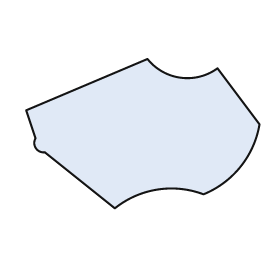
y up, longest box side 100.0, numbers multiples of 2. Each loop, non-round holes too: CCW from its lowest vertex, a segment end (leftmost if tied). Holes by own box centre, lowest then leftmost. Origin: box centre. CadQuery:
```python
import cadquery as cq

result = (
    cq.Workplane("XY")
    .moveTo(-12.0, -32.0)
    .threePointArc((6.0, -24.0), (26.0, -26.0))
    .threePointArc((42.0, -14.0), (50.0, 4.0))
    .lineTo(32.0, 28.0)
    .threePointArc((16.0, 24.0), (2.0, 32.0))
    .lineTo(-50.0, 10.0)
    .lineTo(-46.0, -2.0)
    .threePointArc((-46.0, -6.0), (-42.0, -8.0))
    .close()
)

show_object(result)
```